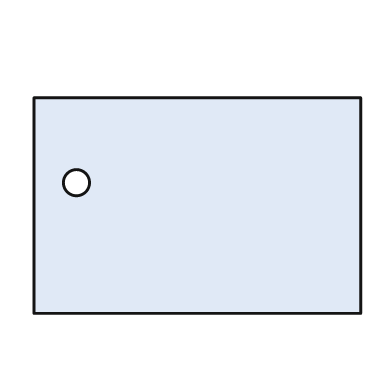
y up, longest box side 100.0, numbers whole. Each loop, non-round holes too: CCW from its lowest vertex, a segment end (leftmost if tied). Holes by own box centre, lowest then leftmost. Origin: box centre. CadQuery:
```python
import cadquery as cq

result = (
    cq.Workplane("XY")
    .moveTo(-50.0, -33.0)
    .lineTo(50.0, -33.0)
    .lineTo(50.0, 33.0)
    .lineTo(-50.0, 33.0)
    .close()
    .moveTo(-37.0, 7.0)
    .circle(4.0)
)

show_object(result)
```